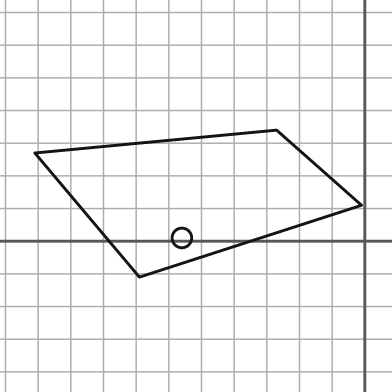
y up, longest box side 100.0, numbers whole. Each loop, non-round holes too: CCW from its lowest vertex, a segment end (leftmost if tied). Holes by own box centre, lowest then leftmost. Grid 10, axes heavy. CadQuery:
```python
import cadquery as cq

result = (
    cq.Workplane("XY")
    .moveTo(-69.0, -11.0)
    .lineTo(-1.0, 11.0)
    .lineTo(-27.0, 34.0)
    .lineTo(-101.0, 27.0)
    .close()
    .moveTo(-56.0, 1.0)
    .circle(3.0)
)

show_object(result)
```